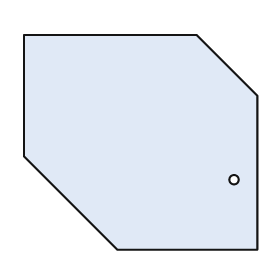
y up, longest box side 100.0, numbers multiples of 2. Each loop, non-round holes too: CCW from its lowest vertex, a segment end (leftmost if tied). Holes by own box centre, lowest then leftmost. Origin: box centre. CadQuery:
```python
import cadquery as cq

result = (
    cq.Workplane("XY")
    .moveTo(-10.0, -46.0)
    .lineTo(50.0, -46.0)
    .lineTo(50.0, 20.0)
    .lineTo(24.0, 46.0)
    .lineTo(-50.0, 46.0)
    .lineTo(-50.0, -6.0)
    .close()
    .moveTo(40.0, -16.0)
    .circle(2.0)
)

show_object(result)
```